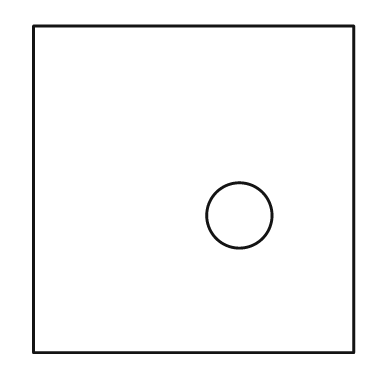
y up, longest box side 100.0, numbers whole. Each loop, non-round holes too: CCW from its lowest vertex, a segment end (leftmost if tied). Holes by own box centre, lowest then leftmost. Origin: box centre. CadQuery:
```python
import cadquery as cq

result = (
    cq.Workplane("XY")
    .moveTo(-49.0, -50.0)
    .lineTo(49.0, -50.0)
    .lineTo(49.0, 50.0)
    .lineTo(-49.0, 50.0)
    .close()
    .moveTo(14.0, -8.0)
    .circle(10.0)
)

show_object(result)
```